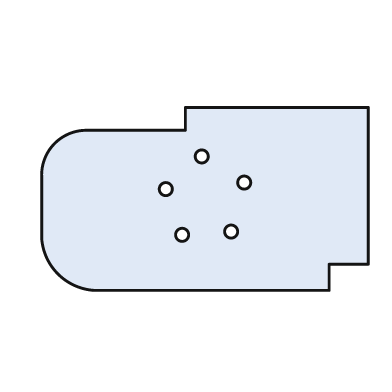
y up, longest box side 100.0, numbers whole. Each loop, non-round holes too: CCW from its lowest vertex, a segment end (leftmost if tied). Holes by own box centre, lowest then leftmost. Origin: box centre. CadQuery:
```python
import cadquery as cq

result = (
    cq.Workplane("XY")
    .moveTo(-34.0, -28.0)
    .lineTo(38.0, -28.0)
    .lineTo(38.0, -20.0)
    .lineTo(50.0, -20.0)
    .lineTo(50.0, 28.0)
    .lineTo(-6.0, 28.0)
    .lineTo(-6.0, 21.0)
    .lineTo(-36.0, 21.0)
    .threePointArc((-46.0, 17.0), (-50.0, 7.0))
    .lineTo(-50.0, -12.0)
    .threePointArc((-45.0, -23.0), (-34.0, -28.0))
    .close()
    .moveTo(-7.0, -11.0)
    .circle(2.0)
    .moveTo(8.0, -10.0)
    .circle(2.0)
    .moveTo(-12.0, 3.0)
    .circle(2.0)
    .moveTo(12.0, 5.0)
    .circle(2.0)
    .moveTo(-1.0, 13.0)
    .circle(2.0)
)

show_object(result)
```